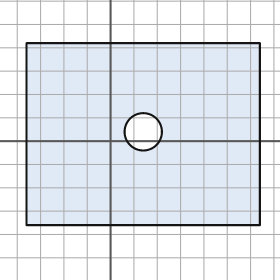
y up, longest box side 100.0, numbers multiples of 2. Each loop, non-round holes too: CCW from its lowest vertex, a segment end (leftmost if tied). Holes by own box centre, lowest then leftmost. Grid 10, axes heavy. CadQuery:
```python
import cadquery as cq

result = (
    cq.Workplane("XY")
    .moveTo(-36.0, -36.0)
    .lineTo(64.0, -36.0)
    .lineTo(64.0, 42.0)
    .lineTo(-36.0, 42.0)
    .close()
    .moveTo(14.0, 4.0)
    .circle(8.0)
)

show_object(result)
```